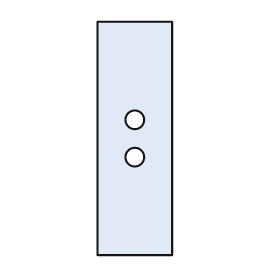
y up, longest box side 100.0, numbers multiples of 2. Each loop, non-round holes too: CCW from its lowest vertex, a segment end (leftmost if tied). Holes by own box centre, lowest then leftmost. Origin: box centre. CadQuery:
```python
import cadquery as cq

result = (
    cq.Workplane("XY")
    .moveTo(-16.0, -50.0)
    .lineTo(16.0, -50.0)
    .lineTo(16.0, 50.0)
    .lineTo(-16.0, 50.0)
    .close()
    .moveTo(0.0, -8.0)
    .circle(4.0)
    .moveTo(0.0, 8.0)
    .circle(4.0)
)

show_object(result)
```